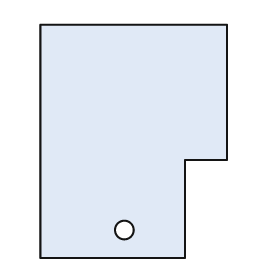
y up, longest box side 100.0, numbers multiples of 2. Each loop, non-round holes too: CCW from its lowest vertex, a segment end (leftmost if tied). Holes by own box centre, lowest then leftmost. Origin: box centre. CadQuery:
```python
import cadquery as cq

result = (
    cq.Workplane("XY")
    .moveTo(-40.0, -50.0)
    .lineTo(22.0, -50.0)
    .lineTo(22.0, -8.0)
    .lineTo(40.0, -8.0)
    .lineTo(40.0, 50.0)
    .lineTo(-40.0, 50.0)
    .close()
    .moveTo(-4.0, -38.0)
    .circle(4.0)
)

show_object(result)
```